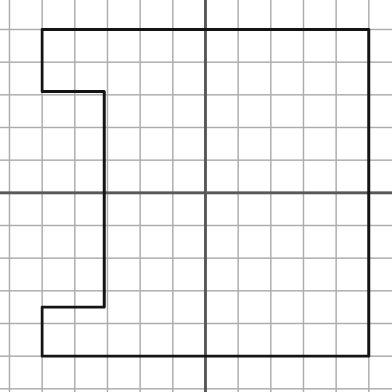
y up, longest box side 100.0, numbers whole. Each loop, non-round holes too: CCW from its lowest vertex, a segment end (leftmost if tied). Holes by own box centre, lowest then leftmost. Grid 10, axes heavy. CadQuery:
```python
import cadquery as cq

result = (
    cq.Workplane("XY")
    .moveTo(-50.0, -50.0)
    .lineTo(50.0, -50.0)
    .lineTo(50.0, 50.0)
    .lineTo(-50.0, 50.0)
    .lineTo(-50.0, 31.0)
    .lineTo(-31.0, 31.0)
    .lineTo(-31.0, -35.0)
    .lineTo(-50.0, -35.0)
    .close()
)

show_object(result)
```